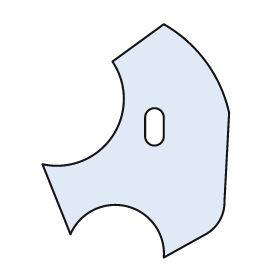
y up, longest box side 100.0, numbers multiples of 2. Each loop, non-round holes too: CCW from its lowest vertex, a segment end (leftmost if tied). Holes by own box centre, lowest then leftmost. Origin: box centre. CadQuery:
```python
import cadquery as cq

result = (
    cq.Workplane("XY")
    .moveTo(12.0, -50.0)
    .lineTo(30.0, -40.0)
    .threePointArc((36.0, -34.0), (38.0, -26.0))
    .lineTo(40.0, 12.0)
    .threePointArc((30.0, 34.0), (12.0, 50.0))
    .lineTo(-10.0, 34.0)
    .threePointArc((-10.0, 2.0), (-40.0, -10.0))
    .lineTo(-28.0, -40.0)
    .threePointArc((-4.0, -28.0), (12.0, -50.0))
    .close()
    .moveTo(4.0, 2.0)
    .threePointArc((8.0, -2.0), (12.0, 2.0))
    .lineTo(12.0, 10.0)
    .threePointArc((8.0, 14.0), (4.0, 10.0))
    .close()
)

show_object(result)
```